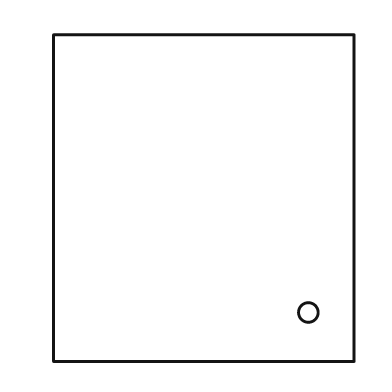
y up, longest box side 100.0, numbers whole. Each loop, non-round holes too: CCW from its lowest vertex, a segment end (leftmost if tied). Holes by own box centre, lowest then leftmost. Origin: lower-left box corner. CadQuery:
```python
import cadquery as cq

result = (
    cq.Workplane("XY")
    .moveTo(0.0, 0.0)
    .lineTo(92.0, 0.0)
    .lineTo(92.0, 100.0)
    .lineTo(0.0, 100.0)
    .close()
    .moveTo(78.0, 15.0)
    .circle(3.0)
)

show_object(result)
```